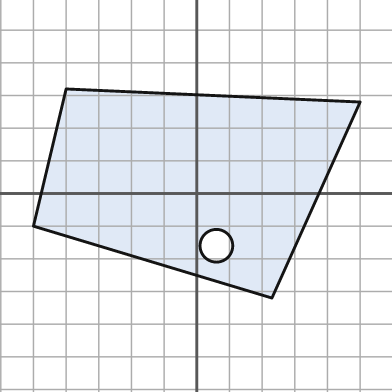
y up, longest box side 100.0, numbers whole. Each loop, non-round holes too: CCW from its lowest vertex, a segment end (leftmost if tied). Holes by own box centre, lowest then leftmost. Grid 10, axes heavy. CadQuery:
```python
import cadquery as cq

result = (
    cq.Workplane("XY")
    .moveTo(23.0, -32.0)
    .lineTo(50.0, 28.0)
    .lineTo(-40.0, 32.0)
    .lineTo(-50.0, -10.0)
    .close()
    .moveTo(6.0, -16.0)
    .circle(5.0)
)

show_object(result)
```